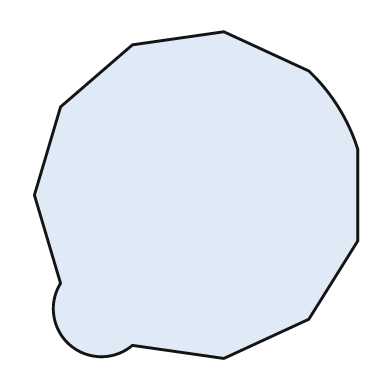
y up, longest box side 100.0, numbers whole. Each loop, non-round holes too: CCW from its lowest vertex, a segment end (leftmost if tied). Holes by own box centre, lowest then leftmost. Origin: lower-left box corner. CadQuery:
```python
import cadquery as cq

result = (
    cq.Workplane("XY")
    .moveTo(58.0, 0.0)
    .lineTo(84.0, 12.0)
    .lineTo(99.0, 36.0)
    .lineTo(99.0, 64.0)
    .threePointArc((93.0, 77.0), (84.0, 88.0))
    .lineTo(58.0, 100.0)
    .lineTo(30.0, 96.0)
    .lineTo(8.0, 77.0)
    .lineTo(0.0, 50.0)
    .lineTo(8.0, 23.0)
    .threePointArc((11.0, 4.0), (30.0, 4.0))
    .close()
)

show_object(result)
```